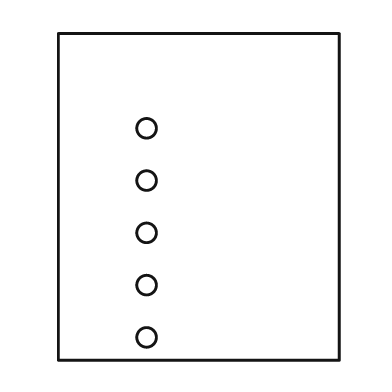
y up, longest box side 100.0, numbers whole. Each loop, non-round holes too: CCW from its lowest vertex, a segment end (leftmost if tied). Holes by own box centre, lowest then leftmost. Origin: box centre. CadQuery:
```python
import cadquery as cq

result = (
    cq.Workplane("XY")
    .moveTo(-43.0, -50.0)
    .lineTo(43.0, -50.0)
    .lineTo(43.0, 50.0)
    .lineTo(-43.0, 50.0)
    .close()
    .moveTo(-16.0, -43.0)
    .circle(3.0)
    .moveTo(-16.0, -27.0)
    .circle(3.0)
    .moveTo(-16.0, -11.0)
    .circle(3.0)
    .moveTo(-16.0, 5.0)
    .circle(3.0)
    .moveTo(-16.0, 21.0)
    .circle(3.0)
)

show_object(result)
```